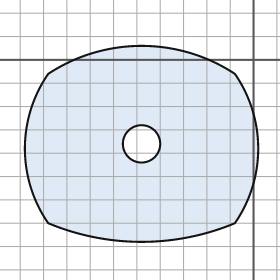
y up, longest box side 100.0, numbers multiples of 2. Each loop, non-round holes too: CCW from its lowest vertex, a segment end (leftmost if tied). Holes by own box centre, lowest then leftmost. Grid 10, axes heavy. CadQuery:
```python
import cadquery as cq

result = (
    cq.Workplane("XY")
    .moveTo(-88.0, -70.0)
    .threePointArc((-48.0, -78.0), (-8.0, -70.0))
    .threePointArc((2.0, -38.0), (-8.0, -6.0))
    .threePointArc((-48.0, 6.0), (-88.0, -6.0))
    .threePointArc((-98.0, -38.0), (-88.0, -70.0))
    .close()
    .moveTo(-48.0, -36.0)
    .circle(8.0)
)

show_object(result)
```